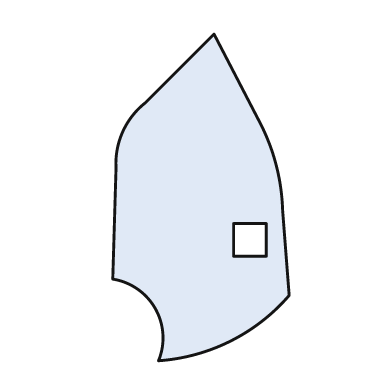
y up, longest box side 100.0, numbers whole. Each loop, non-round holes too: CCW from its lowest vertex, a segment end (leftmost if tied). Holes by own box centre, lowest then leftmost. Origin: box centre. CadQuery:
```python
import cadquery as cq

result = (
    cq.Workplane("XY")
    .moveTo(-13.0, -50.0)
    .threePointArc((9.0, -44.0), (27.0, -30.0))
    .lineTo(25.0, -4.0)
    .threePointArc((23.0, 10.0), (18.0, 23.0))
    .lineTo(4.0, 50.0)
    .lineTo(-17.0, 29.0)
    .threePointArc((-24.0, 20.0), (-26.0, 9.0))
    .lineTo(-27.0, -25.0)
    .threePointArc((-14.0, -34.0), (-13.0, -50.0))
    .close()
    .moveTo(10.0, -18.0)
    .lineTo(20.0, -18.0)
    .lineTo(20.0, -8.0)
    .lineTo(10.0, -8.0)
    .close()
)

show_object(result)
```